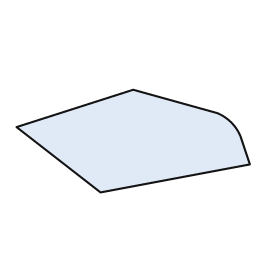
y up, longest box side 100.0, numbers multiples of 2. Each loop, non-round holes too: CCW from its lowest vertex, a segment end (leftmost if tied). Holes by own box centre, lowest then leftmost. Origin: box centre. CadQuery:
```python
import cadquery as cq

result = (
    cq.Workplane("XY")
    .moveTo(-14.0, -22.0)
    .lineTo(50.0, -10.0)
    .lineTo(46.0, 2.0)
    .threePointArc((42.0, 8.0), (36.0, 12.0))
    .lineTo(0.0, 22.0)
    .lineTo(-50.0, 6.0)
    .close()
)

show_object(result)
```